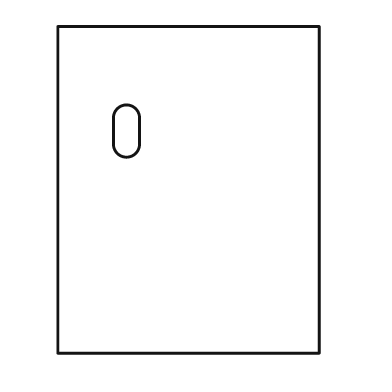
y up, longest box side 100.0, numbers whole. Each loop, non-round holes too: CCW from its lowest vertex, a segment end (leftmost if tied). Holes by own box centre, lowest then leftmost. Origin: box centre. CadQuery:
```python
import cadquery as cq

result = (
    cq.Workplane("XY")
    .moveTo(-40.0, -50.0)
    .lineTo(40.0, -50.0)
    .lineTo(40.0, 50.0)
    .lineTo(-40.0, 50.0)
    .close()
    .moveTo(-23.0, 14.0)
    .threePointArc((-19.0, 10.0), (-15.0, 14.0))
    .lineTo(-15.0, 22.0)
    .threePointArc((-19.0, 26.0), (-23.0, 22.0))
    .close()
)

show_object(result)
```